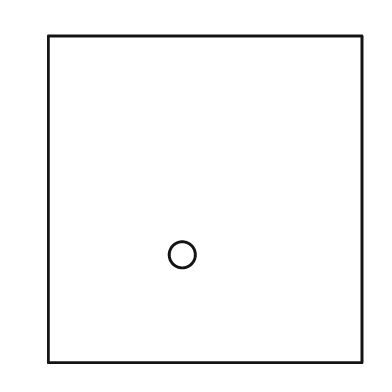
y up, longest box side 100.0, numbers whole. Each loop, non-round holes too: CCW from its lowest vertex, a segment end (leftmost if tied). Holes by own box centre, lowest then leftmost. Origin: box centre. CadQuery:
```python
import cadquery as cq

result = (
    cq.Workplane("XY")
    .moveTo(-48.0, -50.0)
    .lineTo(48.0, -50.0)
    .lineTo(48.0, 50.0)
    .lineTo(-48.0, 50.0)
    .close()
    .moveTo(-7.0, -17.0)
    .circle(4.0)
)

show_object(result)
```